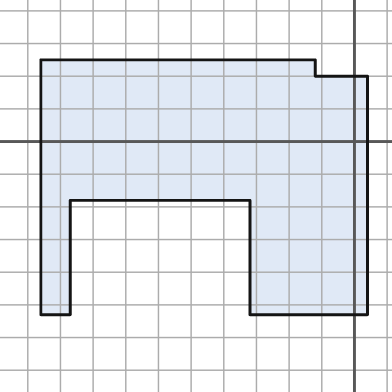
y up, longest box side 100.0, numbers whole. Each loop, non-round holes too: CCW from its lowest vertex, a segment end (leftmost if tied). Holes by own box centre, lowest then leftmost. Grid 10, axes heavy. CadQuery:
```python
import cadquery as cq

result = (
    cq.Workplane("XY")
    .moveTo(-96.0, -53.0)
    .lineTo(-87.0, -53.0)
    .lineTo(-87.0, -18.0)
    .lineTo(-32.0, -18.0)
    .lineTo(-32.0, -53.0)
    .lineTo(4.0, -53.0)
    .lineTo(4.0, 20.0)
    .lineTo(-12.0, 20.0)
    .lineTo(-12.0, 25.0)
    .lineTo(-96.0, 25.0)
    .close()
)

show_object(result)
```